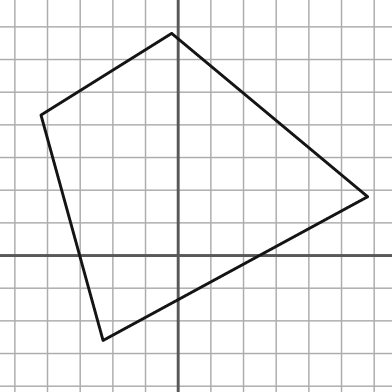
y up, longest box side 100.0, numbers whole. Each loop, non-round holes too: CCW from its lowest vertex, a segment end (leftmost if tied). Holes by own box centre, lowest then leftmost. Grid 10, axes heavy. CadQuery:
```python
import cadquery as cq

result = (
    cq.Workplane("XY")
    .moveTo(-23.0, -26.0)
    .lineTo(58.0, 18.0)
    .lineTo(-2.0, 68.0)
    .lineTo(-42.0, 43.0)
    .close()
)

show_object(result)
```